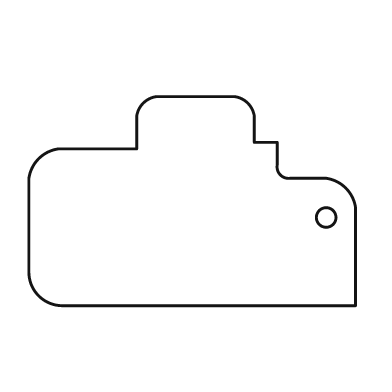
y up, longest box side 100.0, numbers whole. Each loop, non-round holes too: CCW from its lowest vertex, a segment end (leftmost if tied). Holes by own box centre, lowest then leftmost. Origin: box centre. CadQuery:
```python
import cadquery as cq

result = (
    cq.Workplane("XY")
    .moveTo(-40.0, -32.0)
    .lineTo(50.0, -32.0)
    .lineTo(50.0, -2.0)
    .threePointArc((47.0, 4.0), (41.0, 7.0))
    .lineTo(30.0, 7.0)
    .threePointArc((27.0, 8.0), (26.0, 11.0))
    .lineTo(26.0, 18.0)
    .lineTo(19.0, 18.0)
    .lineTo(19.0, 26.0)
    .threePointArc((17.0, 30.0), (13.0, 32.0))
    .lineTo(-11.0, 32.0)
    .threePointArc((-15.0, 30.0), (-17.0, 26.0))
    .lineTo(-17.0, 16.0)
    .lineTo(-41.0, 16.0)
    .threePointArc((-47.0, 13.0), (-50.0, 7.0))
    .lineTo(-50.0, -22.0)
    .threePointArc((-47.0, -29.0), (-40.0, -32.0))
    .close()
    .moveTo(41.0, -5.0)
    .circle(3.0)
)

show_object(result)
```